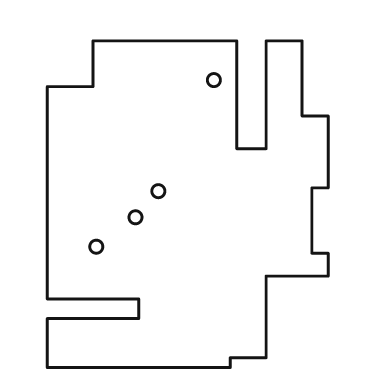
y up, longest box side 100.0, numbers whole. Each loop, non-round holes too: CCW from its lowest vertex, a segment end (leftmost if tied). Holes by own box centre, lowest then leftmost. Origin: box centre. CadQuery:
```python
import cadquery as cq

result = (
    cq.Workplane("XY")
    .moveTo(-43.0, -50.0)
    .lineTo(13.0, -50.0)
    .lineTo(13.0, -47.0)
    .lineTo(24.0, -47.0)
    .lineTo(24.0, -22.0)
    .lineTo(43.0, -22.0)
    .lineTo(43.0, -15.0)
    .lineTo(38.0, -15.0)
    .lineTo(38.0, 5.0)
    .lineTo(43.0, 5.0)
    .lineTo(43.0, 27.0)
    .lineTo(35.0, 27.0)
    .lineTo(35.0, 50.0)
    .lineTo(24.0, 50.0)
    .lineTo(24.0, 17.0)
    .lineTo(15.0, 17.0)
    .lineTo(15.0, 50.0)
    .lineTo(-29.0, 50.0)
    .lineTo(-29.0, 36.0)
    .lineTo(-43.0, 36.0)
    .lineTo(-43.0, -29.0)
    .lineTo(-15.0, -29.0)
    .lineTo(-15.0, -35.0)
    .lineTo(-43.0, -35.0)
    .close()
    .moveTo(-28.0, -13.0)
    .circle(2.0)
    .moveTo(-16.0, -4.0)
    .circle(2.0)
    .moveTo(-9.0, 4.0)
    .circle(2.0)
    .moveTo(8.0, 38.0)
    .circle(2.0)
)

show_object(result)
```